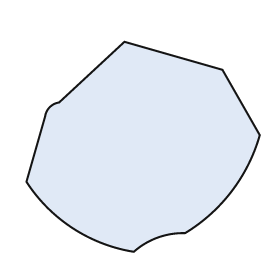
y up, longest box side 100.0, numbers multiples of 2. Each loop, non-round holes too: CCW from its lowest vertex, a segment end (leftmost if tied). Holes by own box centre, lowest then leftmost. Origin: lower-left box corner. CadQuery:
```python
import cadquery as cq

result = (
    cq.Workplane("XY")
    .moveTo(46.0, 0.0)
    .threePointArc((56.0, 6.0), (68.0, 8.0))
    .threePointArc((88.0, 26.0), (100.0, 50.0))
    .lineTo(84.0, 78.0)
    .lineTo(42.0, 90.0)
    .lineTo(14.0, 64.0)
    .threePointArc((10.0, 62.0), (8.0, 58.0))
    .lineTo(0.0, 30.0)
    .threePointArc((20.0, 10.0), (46.0, 0.0))
    .close()
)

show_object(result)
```